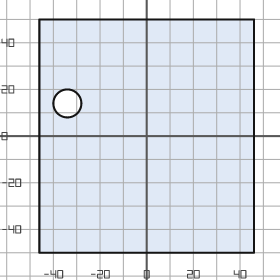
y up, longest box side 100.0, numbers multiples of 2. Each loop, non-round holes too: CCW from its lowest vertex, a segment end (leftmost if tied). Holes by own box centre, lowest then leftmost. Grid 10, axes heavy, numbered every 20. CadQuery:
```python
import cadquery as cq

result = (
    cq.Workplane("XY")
    .moveTo(-46.0, -50.0)
    .lineTo(46.0, -50.0)
    .lineTo(46.0, 50.0)
    .lineTo(-46.0, 50.0)
    .close()
    .moveTo(-34.0, 14.0)
    .circle(6.0)
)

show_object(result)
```